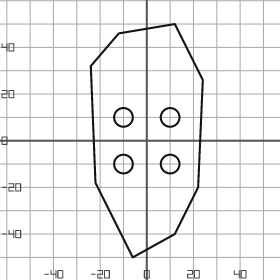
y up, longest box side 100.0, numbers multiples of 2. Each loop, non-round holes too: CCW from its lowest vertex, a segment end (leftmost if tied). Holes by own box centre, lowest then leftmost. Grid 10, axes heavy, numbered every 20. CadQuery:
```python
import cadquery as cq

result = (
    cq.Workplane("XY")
    .moveTo(-6.0, -50.0)
    .lineTo(12.0, -40.0)
    .lineTo(22.0, -20.0)
    .lineTo(24.0, 26.0)
    .lineTo(12.0, 50.0)
    .lineTo(-12.0, 46.0)
    .lineTo(-24.0, 32.0)
    .lineTo(-22.0, -18.0)
    .close()
    .moveTo(-10.0, -10.0)
    .circle(4.0)
    .moveTo(10.0, -10.0)
    .circle(4.0)
    .moveTo(-10.0, 10.0)
    .circle(4.0)
    .moveTo(10.0, 10.0)
    .circle(4.0)
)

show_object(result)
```